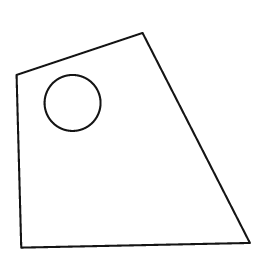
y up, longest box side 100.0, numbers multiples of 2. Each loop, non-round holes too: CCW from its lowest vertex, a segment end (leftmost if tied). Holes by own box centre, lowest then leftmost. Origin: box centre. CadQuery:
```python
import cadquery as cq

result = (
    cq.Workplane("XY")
    .moveTo(-48.0, -46.0)
    .lineTo(50.0, -44.0)
    .lineTo(4.0, 46.0)
    .lineTo(-50.0, 28.0)
    .close()
    .moveTo(-26.0, 16.0)
    .circle(12.0)
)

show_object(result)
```